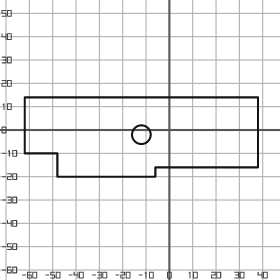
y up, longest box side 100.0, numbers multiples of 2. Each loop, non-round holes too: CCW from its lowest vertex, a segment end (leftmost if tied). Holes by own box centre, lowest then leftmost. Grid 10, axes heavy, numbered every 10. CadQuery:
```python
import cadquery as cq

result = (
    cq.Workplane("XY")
    .moveTo(-48.0, -20.0)
    .lineTo(-6.0, -20.0)
    .lineTo(-6.0, -16.0)
    .lineTo(38.0, -16.0)
    .lineTo(38.0, 14.0)
    .lineTo(-62.0, 14.0)
    .lineTo(-62.0, -10.0)
    .lineTo(-48.0, -10.0)
    .close()
    .moveTo(-12.0, -2.0)
    .circle(4.0)
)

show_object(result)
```